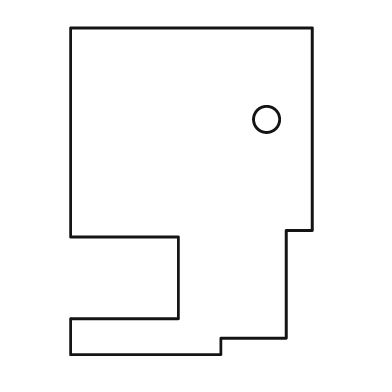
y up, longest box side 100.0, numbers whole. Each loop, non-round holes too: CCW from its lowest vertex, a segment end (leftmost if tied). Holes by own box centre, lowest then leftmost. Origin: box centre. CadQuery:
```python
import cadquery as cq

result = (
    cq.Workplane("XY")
    .moveTo(-37.0, -50.0)
    .lineTo(9.0, -50.0)
    .lineTo(9.0, -45.0)
    .lineTo(29.0, -45.0)
    .lineTo(29.0, -12.0)
    .lineTo(37.0, -12.0)
    .lineTo(37.0, 50.0)
    .lineTo(-37.0, 50.0)
    .lineTo(-37.0, -14.0)
    .lineTo(-4.0, -14.0)
    .lineTo(-4.0, -39.0)
    .lineTo(-37.0, -39.0)
    .close()
    .moveTo(23.0, 22.0)
    .circle(4.0)
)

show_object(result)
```